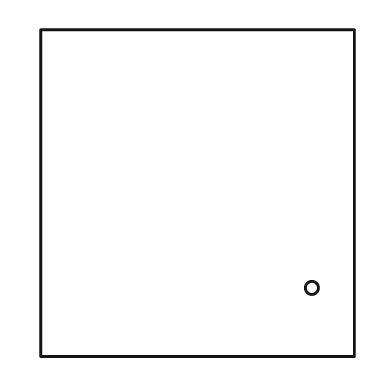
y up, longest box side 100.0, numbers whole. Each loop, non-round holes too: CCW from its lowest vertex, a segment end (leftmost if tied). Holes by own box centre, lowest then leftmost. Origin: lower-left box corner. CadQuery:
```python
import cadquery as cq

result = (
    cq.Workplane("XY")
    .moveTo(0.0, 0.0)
    .lineTo(96.0, 0.0)
    .lineTo(96.0, 100.0)
    .lineTo(0.0, 100.0)
    .close()
    .moveTo(83.0, 21.0)
    .circle(2.0)
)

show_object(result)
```